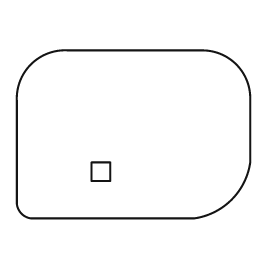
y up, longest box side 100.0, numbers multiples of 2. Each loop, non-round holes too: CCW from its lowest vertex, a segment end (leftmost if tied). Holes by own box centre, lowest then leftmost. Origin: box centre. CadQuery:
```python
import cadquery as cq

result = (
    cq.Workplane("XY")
    .moveTo(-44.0, -36.0)
    .lineTo(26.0, -36.0)
    .threePointArc((42.0, -28.0), (50.0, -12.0))
    .lineTo(50.0, 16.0)
    .threePointArc((44.0, 30.0), (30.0, 36.0))
    .lineTo(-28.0, 36.0)
    .threePointArc((-44.0, 30.0), (-50.0, 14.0))
    .lineTo(-50.0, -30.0)
    .threePointArc((-48.0, -34.0), (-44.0, -36.0))
    .close()
    .moveTo(-18.0, -20.0)
    .lineTo(-10.0, -20.0)
    .lineTo(-10.0, -12.0)
    .lineTo(-18.0, -12.0)
    .close()
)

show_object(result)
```